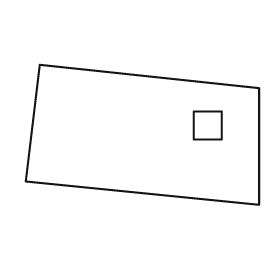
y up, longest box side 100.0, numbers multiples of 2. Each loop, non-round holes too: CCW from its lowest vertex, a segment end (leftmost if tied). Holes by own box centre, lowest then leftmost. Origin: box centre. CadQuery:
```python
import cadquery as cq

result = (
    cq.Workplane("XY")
    .moveTo(50.0, -30.0)
    .lineTo(50.0, 20.0)
    .lineTo(-44.0, 30.0)
    .lineTo(-50.0, -20.0)
    .close()
    .moveTo(22.0, -2.0)
    .lineTo(34.0, -2.0)
    .lineTo(34.0, 10.0)
    .lineTo(22.0, 10.0)
    .close()
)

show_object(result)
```